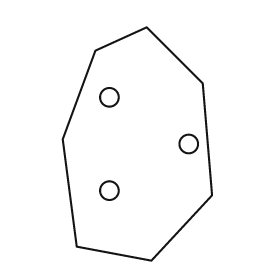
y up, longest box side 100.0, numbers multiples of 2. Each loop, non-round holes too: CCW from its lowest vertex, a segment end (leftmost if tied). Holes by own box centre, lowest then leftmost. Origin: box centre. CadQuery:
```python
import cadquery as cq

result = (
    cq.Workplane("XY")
    .moveTo(6.0, -50.0)
    .lineTo(32.0, -22.0)
    .lineTo(28.0, 26.0)
    .lineTo(4.0, 50.0)
    .lineTo(-18.0, 40.0)
    .lineTo(-32.0, 2.0)
    .lineTo(-26.0, -44.0)
    .close()
    .moveTo(-12.0, -20.0)
    .circle(4.0)
    .moveTo(22.0, 0.0)
    .circle(4.0)
    .moveTo(-12.0, 20.0)
    .circle(4.0)
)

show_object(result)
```